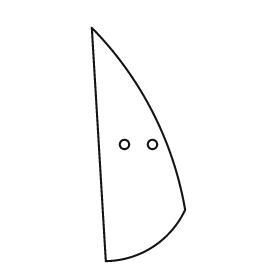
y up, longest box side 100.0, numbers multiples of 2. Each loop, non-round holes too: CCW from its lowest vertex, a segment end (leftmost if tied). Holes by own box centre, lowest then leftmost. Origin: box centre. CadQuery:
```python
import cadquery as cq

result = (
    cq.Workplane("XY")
    .moveTo(-14.0, -50.0)
    .threePointArc((6.0, -44.0), (20.0, -28.0))
    .threePointArc((6.0, 14.0), (-20.0, 50.0))
    .close()
    .moveTo(-6.0, 0.0)
    .circle(2.0)
    .moveTo(6.0, 0.0)
    .circle(2.0)
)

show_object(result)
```